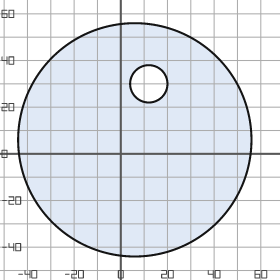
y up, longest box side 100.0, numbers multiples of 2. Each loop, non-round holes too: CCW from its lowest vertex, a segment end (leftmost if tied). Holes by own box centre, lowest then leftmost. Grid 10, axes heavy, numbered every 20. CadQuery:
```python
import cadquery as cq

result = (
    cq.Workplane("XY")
    .moveTo(6.0, 6.0)
    .circle(50.0)
    .moveTo(12.0, 30.0)
    .circle(8.0)
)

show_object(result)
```